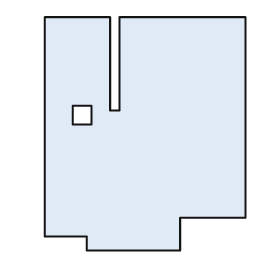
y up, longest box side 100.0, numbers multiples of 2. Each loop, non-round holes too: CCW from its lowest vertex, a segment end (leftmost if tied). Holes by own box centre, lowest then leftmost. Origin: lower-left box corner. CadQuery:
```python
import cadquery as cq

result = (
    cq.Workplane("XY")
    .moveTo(18.0, 0.0)
    .lineTo(58.0, 0.0)
    .lineTo(58.0, 14.0)
    .lineTo(86.0, 14.0)
    .lineTo(86.0, 100.0)
    .lineTo(32.0, 100.0)
    .lineTo(32.0, 60.0)
    .lineTo(28.0, 60.0)
    .lineTo(28.0, 100.0)
    .lineTo(0.0, 100.0)
    .lineTo(0.0, 6.0)
    .lineTo(18.0, 6.0)
    .close()
    .moveTo(12.0, 54.0)
    .lineTo(20.0, 54.0)
    .lineTo(20.0, 62.0)
    .lineTo(12.0, 62.0)
    .close()
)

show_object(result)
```